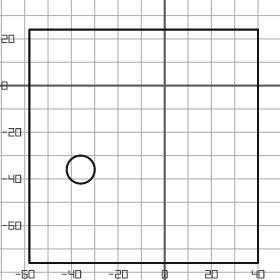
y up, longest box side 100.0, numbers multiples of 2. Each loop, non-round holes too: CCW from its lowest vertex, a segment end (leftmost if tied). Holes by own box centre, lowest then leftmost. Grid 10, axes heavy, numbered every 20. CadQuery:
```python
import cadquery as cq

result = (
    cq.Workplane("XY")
    .moveTo(-58.0, -76.0)
    .lineTo(40.0, -76.0)
    .lineTo(40.0, 24.0)
    .lineTo(-58.0, 24.0)
    .close()
    .moveTo(-36.0, -36.0)
    .circle(6.0)
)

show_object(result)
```